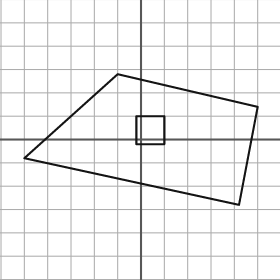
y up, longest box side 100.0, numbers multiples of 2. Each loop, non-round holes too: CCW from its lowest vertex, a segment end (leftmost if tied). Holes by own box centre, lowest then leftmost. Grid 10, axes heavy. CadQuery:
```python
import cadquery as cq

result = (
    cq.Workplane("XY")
    .moveTo(42.0, -28.0)
    .lineTo(50.0, 14.0)
    .lineTo(-10.0, 28.0)
    .lineTo(-50.0, -8.0)
    .close()
    .moveTo(-2.0, -2.0)
    .lineTo(10.0, -2.0)
    .lineTo(10.0, 10.0)
    .lineTo(-2.0, 10.0)
    .close()
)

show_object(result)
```